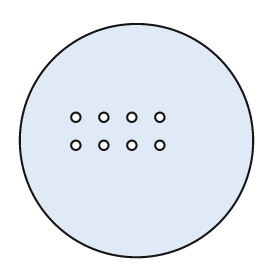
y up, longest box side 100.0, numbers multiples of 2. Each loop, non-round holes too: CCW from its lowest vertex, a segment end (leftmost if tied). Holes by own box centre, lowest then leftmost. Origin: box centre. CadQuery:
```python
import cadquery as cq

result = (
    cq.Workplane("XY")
    .moveTo(0.0, 0.0)
    .circle(50.0)
    .moveTo(-26.0, -2.0)
    .circle(2.0)
    .moveTo(-14.0, -2.0)
    .circle(2.0)
    .moveTo(-2.0, -2.0)
    .circle(2.0)
    .moveTo(10.0, -2.0)
    .circle(2.0)
    .moveTo(-26.0, 10.0)
    .circle(2.0)
    .moveTo(-14.0, 10.0)
    .circle(2.0)
    .moveTo(-2.0, 10.0)
    .circle(2.0)
    .moveTo(10.0, 10.0)
    .circle(2.0)
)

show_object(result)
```